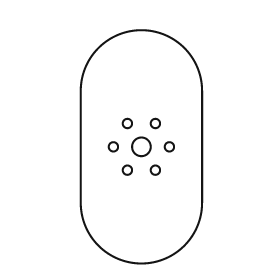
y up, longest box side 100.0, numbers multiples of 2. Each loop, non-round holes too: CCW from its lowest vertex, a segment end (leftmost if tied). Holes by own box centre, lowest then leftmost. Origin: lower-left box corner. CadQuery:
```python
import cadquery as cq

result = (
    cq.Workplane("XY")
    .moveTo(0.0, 26.0)
    .threePointArc((26.0, 0.0), (52.0, 26.0))
    .lineTo(52.0, 74.0)
    .threePointArc((26.0, 100.0), (0.0, 74.0))
    .close()
    .moveTo(20.0, 40.0)
    .circle(2.0)
    .moveTo(32.0, 40.0)
    .circle(2.0)
    .moveTo(14.0, 50.0)
    .circle(2.0)
    .moveTo(26.0, 50.0)
    .circle(4.0)
    .moveTo(38.0, 50.0)
    .circle(2.0)
    .moveTo(20.0, 60.0)
    .circle(2.0)
    .moveTo(32.0, 60.0)
    .circle(2.0)
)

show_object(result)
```